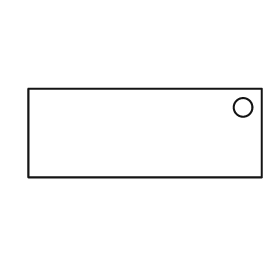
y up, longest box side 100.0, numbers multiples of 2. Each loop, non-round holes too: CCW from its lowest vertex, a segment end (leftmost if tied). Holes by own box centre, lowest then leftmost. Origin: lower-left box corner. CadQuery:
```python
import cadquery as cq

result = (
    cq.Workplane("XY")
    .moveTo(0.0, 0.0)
    .lineTo(100.0, 0.0)
    .lineTo(100.0, 38.0)
    .lineTo(0.0, 38.0)
    .close()
    .moveTo(92.0, 30.0)
    .circle(4.0)
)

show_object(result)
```